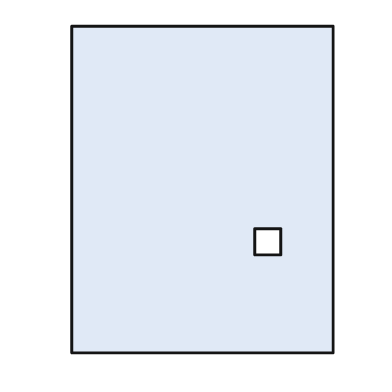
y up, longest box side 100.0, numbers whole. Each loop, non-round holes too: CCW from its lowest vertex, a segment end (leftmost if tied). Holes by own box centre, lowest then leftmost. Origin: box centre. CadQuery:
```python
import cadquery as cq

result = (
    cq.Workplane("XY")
    .moveTo(-40.0, -50.0)
    .lineTo(40.0, -50.0)
    .lineTo(40.0, 50.0)
    .lineTo(-40.0, 50.0)
    .close()
    .moveTo(16.0, -20.0)
    .lineTo(24.0, -20.0)
    .lineTo(24.0, -12.0)
    .lineTo(16.0, -12.0)
    .close()
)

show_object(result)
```